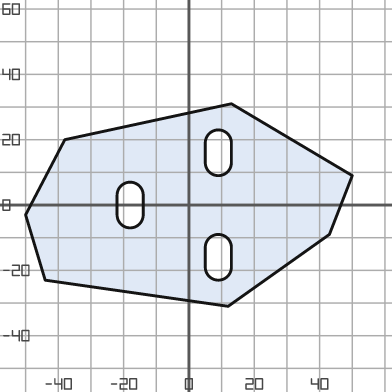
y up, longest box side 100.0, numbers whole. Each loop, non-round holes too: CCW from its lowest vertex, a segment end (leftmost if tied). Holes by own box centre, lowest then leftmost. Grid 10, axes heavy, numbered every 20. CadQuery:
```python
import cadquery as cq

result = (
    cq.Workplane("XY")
    .moveTo(12.0, -31.0)
    .lineTo(43.0, -9.0)
    .lineTo(50.0, 9.0)
    .lineTo(13.0, 31.0)
    .lineTo(-38.0, 20.0)
    .lineTo(-50.0, -3.0)
    .lineTo(-44.0, -23.0)
    .close()
    .moveTo(5.0, -19.0)
    .threePointArc((9.0, -23.0), (13.0, -19.0))
    .lineTo(13.0, -13.0)
    .threePointArc((9.0, -9.0), (5.0, -13.0))
    .close()
    .moveTo(-22.0, -3.0)
    .threePointArc((-18.0, -7.0), (-14.0, -3.0))
    .lineTo(-14.0, 3.0)
    .threePointArc((-18.0, 7.0), (-22.0, 3.0))
    .close()
    .moveTo(5.0, 13.0)
    .threePointArc((9.0, 9.0), (13.0, 13.0))
    .lineTo(13.0, 19.0)
    .threePointArc((9.0, 23.0), (5.0, 19.0))
    .close()
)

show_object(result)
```